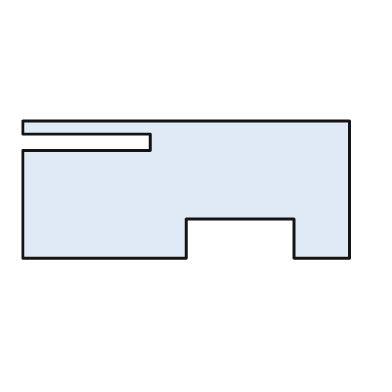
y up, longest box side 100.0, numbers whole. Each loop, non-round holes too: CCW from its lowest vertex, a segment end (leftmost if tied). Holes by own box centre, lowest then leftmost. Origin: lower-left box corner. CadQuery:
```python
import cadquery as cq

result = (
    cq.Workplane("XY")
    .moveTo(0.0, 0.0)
    .lineTo(50.0, 0.0)
    .lineTo(50.0, 12.0)
    .lineTo(83.0, 12.0)
    .lineTo(83.0, 0.0)
    .lineTo(100.0, 0.0)
    .lineTo(100.0, 42.0)
    .lineTo(0.0, 42.0)
    .lineTo(0.0, 38.0)
    .lineTo(39.0, 38.0)
    .lineTo(39.0, 33.0)
    .lineTo(0.0, 33.0)
    .close()
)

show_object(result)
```